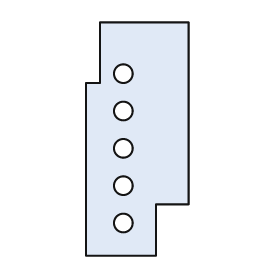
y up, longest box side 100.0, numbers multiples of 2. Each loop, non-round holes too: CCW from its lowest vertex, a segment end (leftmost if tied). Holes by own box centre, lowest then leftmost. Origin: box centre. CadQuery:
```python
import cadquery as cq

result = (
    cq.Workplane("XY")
    .moveTo(-22.0, -50.0)
    .lineTo(8.0, -50.0)
    .lineTo(8.0, -28.0)
    .lineTo(22.0, -28.0)
    .lineTo(22.0, 50.0)
    .lineTo(-16.0, 50.0)
    .lineTo(-16.0, 24.0)
    .lineTo(-22.0, 24.0)
    .close()
    .moveTo(-6.0, -36.0)
    .circle(4.0)
    .moveTo(-6.0, -20.0)
    .circle(4.0)
    .moveTo(-6.0, -4.0)
    .circle(4.0)
    .moveTo(-6.0, 12.0)
    .circle(4.0)
    .moveTo(-6.0, 28.0)
    .circle(4.0)
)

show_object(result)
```